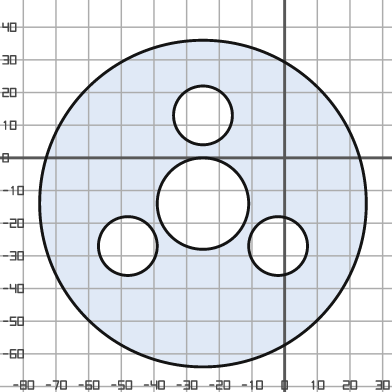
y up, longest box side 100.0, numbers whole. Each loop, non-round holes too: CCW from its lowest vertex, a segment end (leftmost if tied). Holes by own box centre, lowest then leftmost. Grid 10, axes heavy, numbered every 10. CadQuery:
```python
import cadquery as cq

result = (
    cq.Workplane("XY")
    .moveTo(-25.0, -14.0)
    .circle(50.0)
    .moveTo(-48.0, -27.0)
    .circle(9.0)
    .moveTo(-2.0, -27.0)
    .circle(9.0)
    .moveTo(-25.0, -14.0)
    .circle(14.0)
    .moveTo(-25.0, 13.0)
    .circle(9.0)
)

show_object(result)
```